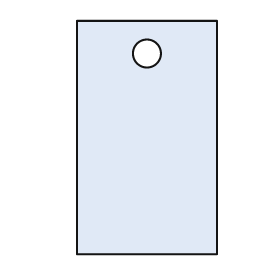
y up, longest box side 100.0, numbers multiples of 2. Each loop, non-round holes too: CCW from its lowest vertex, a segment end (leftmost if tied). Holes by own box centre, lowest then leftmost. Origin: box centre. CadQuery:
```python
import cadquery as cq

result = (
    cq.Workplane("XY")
    .moveTo(-30.0, -50.0)
    .lineTo(30.0, -50.0)
    .lineTo(30.0, 50.0)
    .lineTo(-30.0, 50.0)
    .close()
    .moveTo(0.0, 36.0)
    .circle(6.0)
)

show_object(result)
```